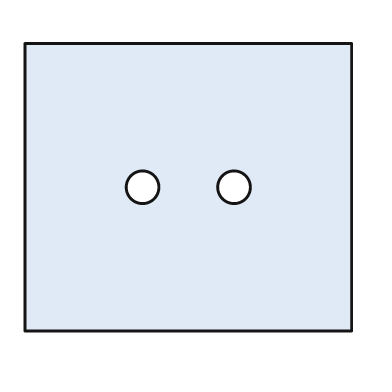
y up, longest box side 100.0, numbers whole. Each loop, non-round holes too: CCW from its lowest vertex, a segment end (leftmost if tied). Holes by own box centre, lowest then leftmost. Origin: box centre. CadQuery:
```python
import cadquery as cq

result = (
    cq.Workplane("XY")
    .moveTo(-50.0, -44.0)
    .lineTo(50.0, -44.0)
    .lineTo(50.0, 44.0)
    .lineTo(-50.0, 44.0)
    .close()
    .moveTo(-14.0, 0.0)
    .circle(5.0)
    .moveTo(14.0, 0.0)
    .circle(5.0)
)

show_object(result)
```